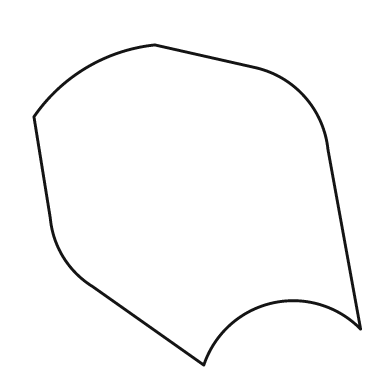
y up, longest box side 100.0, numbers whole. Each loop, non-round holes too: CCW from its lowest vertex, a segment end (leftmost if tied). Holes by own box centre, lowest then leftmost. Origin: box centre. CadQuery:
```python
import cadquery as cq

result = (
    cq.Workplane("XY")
    .moveTo(2.0, -49.0)
    .threePointArc((23.0, -30.0), (50.0, -38.0))
    .lineTo(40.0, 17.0)
    .threePointArc((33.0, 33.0), (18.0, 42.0))
    .lineTo(-13.0, 49.0)
    .threePointArc((-34.0, 42.0), (-50.0, 27.0))
    .lineTo(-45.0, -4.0)
    .threePointArc((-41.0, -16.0), (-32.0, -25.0))
    .close()
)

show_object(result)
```